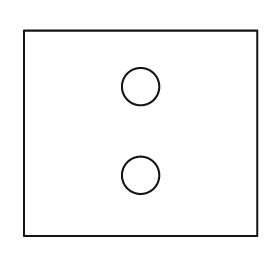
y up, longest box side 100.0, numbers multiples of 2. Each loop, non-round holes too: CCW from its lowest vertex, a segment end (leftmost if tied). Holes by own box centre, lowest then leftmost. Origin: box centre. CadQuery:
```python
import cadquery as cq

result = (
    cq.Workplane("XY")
    .moveTo(-50.0, -44.0)
    .lineTo(50.0, -44.0)
    .lineTo(50.0, 44.0)
    .lineTo(-50.0, 44.0)
    .close()
    .moveTo(0.0, -18.0)
    .circle(8.0)
    .moveTo(0.0, 20.0)
    .circle(8.0)
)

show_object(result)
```